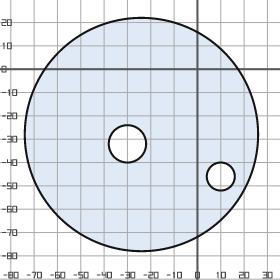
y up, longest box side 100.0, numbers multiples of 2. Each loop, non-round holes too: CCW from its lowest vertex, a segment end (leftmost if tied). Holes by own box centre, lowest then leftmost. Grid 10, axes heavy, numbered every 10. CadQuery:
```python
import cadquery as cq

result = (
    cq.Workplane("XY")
    .moveTo(-24.0, -28.0)
    .circle(50.0)
    .moveTo(10.0, -46.0)
    .circle(6.0)
    .moveTo(-30.0, -32.0)
    .circle(8.0)
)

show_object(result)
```